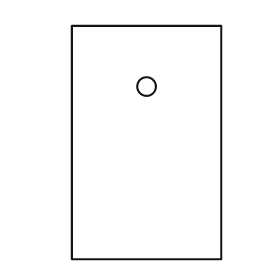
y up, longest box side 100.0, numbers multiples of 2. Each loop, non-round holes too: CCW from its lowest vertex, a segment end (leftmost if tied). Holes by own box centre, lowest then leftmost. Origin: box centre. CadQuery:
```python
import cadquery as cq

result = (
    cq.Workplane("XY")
    .moveTo(-32.0, -50.0)
    .lineTo(32.0, -50.0)
    .lineTo(32.0, 50.0)
    .lineTo(-32.0, 50.0)
    .close()
    .moveTo(0.0, 24.0)
    .circle(4.0)
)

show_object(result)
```